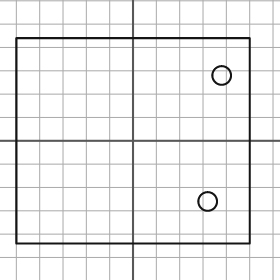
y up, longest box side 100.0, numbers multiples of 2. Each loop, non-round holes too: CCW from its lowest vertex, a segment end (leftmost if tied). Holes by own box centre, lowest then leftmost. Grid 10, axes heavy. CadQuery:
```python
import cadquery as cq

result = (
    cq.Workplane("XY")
    .moveTo(-50.0, -44.0)
    .lineTo(50.0, -44.0)
    .lineTo(50.0, 44.0)
    .lineTo(-50.0, 44.0)
    .close()
    .moveTo(32.0, -26.0)
    .circle(4.0)
    .moveTo(38.0, 28.0)
    .circle(4.0)
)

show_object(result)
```